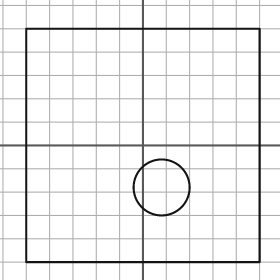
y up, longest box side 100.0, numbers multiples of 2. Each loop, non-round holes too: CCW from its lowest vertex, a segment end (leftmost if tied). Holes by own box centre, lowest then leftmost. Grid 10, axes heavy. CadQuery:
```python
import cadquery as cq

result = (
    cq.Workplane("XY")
    .moveTo(-50.0, -50.0)
    .lineTo(50.0, -50.0)
    .lineTo(50.0, 50.0)
    .lineTo(-50.0, 50.0)
    .close()
    .moveTo(8.0, -18.0)
    .circle(12.0)
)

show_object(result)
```